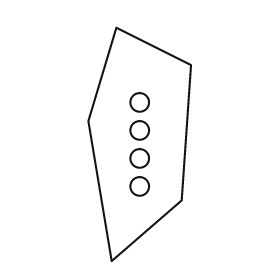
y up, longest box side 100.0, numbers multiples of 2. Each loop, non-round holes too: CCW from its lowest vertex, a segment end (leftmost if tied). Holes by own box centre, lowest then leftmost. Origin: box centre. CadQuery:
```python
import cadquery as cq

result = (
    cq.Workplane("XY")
    .moveTo(-12.0, -50.0)
    .lineTo(18.0, -24.0)
    .lineTo(22.0, 34.0)
    .lineTo(-10.0, 50.0)
    .lineTo(-22.0, 10.0)
    .close()
    .moveTo(0.0, -18.0)
    .circle(4.0)
    .moveTo(0.0, -6.0)
    .circle(4.0)
    .moveTo(0.0, 6.0)
    .circle(4.0)
    .moveTo(0.0, 18.0)
    .circle(4.0)
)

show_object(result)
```